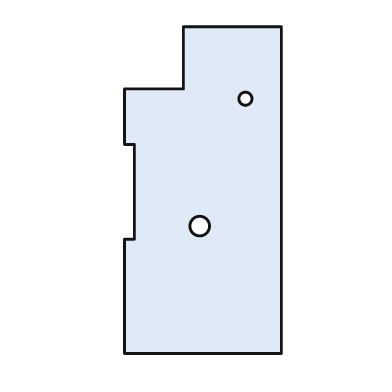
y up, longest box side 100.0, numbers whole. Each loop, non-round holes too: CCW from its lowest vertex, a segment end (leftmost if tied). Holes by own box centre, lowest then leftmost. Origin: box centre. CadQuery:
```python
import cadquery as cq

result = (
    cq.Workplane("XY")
    .moveTo(-24.0, -50.0)
    .lineTo(24.0, -50.0)
    .lineTo(24.0, 50.0)
    .lineTo(-6.0, 50.0)
    .lineTo(-6.0, 31.0)
    .lineTo(-24.0, 31.0)
    .lineTo(-24.0, 14.0)
    .lineTo(-21.0, 14.0)
    .lineTo(-21.0, -15.0)
    .lineTo(-24.0, -15.0)
    .close()
    .moveTo(-1.0, -11.0)
    .circle(3.0)
    .moveTo(13.0, 28.0)
    .circle(2.0)
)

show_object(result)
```